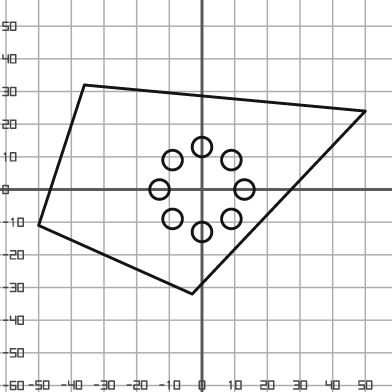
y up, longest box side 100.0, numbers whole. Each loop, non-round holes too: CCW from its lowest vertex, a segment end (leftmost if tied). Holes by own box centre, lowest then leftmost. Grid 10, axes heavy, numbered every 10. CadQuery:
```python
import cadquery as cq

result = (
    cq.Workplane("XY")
    .moveTo(-3.0, -32.0)
    .lineTo(50.0, 24.0)
    .lineTo(-36.0, 32.0)
    .lineTo(-50.0, -11.0)
    .close()
    .moveTo(0.0, -13.0)
    .circle(3.0)
    .moveTo(-9.0, -9.0)
    .circle(3.0)
    .moveTo(9.0, -9.0)
    .circle(3.0)
    .moveTo(-13.0, 0.0)
    .circle(3.0)
    .moveTo(13.0, 0.0)
    .circle(3.0)
    .moveTo(-9.0, 9.0)
    .circle(3.0)
    .moveTo(9.0, 9.0)
    .circle(3.0)
    .moveTo(0.0, 13.0)
    .circle(3.0)
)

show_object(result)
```